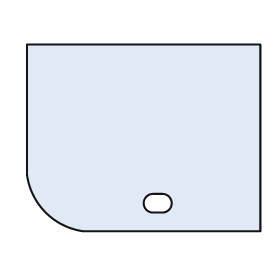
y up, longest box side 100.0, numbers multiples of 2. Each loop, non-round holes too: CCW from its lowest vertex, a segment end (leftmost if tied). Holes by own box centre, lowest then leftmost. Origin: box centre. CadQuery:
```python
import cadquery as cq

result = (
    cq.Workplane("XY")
    .moveTo(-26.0, -40.0)
    .lineTo(50.0, -40.0)
    .lineTo(50.0, 40.0)
    .lineTo(-50.0, 40.0)
    .lineTo(-50.0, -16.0)
    .threePointArc((-42.0, -32.0), (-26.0, -40.0))
    .close()
    .moveTo(4.0, -32.0)
    .lineTo(8.0, -32.0)
    .threePointArc((12.0, -28.0), (8.0, -24.0))
    .lineTo(4.0, -24.0)
    .threePointArc((0.0, -28.0), (4.0, -32.0))
    .close()
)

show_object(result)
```